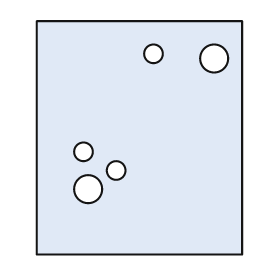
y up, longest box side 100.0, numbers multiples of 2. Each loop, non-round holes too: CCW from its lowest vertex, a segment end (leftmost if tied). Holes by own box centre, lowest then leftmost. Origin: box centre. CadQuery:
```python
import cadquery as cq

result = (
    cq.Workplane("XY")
    .moveTo(-44.0, -50.0)
    .lineTo(44.0, -50.0)
    .lineTo(44.0, 50.0)
    .lineTo(-44.0, 50.0)
    .close()
    .moveTo(-22.0, -22.0)
    .circle(6.0)
    .moveTo(-10.0, -14.0)
    .circle(4.0)
    .moveTo(-24.0, -6.0)
    .circle(4.0)
    .moveTo(32.0, 34.0)
    .circle(6.0)
    .moveTo(6.0, 36.0)
    .circle(4.0)
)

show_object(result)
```